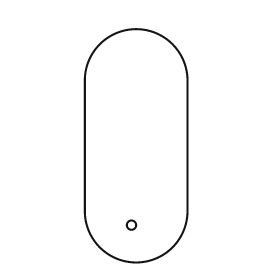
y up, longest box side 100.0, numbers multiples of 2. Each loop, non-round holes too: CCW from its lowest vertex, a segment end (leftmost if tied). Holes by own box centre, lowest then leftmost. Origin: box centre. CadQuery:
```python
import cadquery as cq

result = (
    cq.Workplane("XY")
    .moveTo(-22.0, -28.0)
    .threePointArc((0.0, -50.0), (22.0, -28.0))
    .lineTo(22.0, 28.0)
    .threePointArc((0.0, 50.0), (-22.0, 28.0))
    .close()
    .moveTo(-2.0, -34.0)
    .circle(2.0)
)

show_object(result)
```